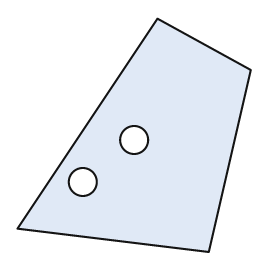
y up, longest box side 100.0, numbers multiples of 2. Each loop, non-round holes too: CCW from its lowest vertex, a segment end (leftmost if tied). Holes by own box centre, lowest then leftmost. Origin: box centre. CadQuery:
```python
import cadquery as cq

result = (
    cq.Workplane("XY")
    .moveTo(32.0, -50.0)
    .lineTo(50.0, 28.0)
    .lineTo(10.0, 50.0)
    .lineTo(-50.0, -40.0)
    .close()
    .moveTo(-22.0, -20.0)
    .circle(6.0)
    .moveTo(0.0, -2.0)
    .circle(6.0)
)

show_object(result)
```